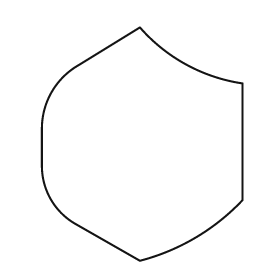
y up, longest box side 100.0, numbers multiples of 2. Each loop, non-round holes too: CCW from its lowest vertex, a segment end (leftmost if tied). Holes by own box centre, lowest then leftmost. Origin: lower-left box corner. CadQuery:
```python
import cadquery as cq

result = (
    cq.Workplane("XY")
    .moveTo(42.0, 0.0)
    .threePointArc((66.0, 10.0), (86.0, 26.0))
    .lineTo(86.0, 76.0)
    .threePointArc((62.0, 84.0), (42.0, 100.0))
    .lineTo(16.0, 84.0)
    .threePointArc((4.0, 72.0), (0.0, 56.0))
    .lineTo(0.0, 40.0)
    .threePointArc((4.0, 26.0), (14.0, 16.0))
    .close()
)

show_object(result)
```